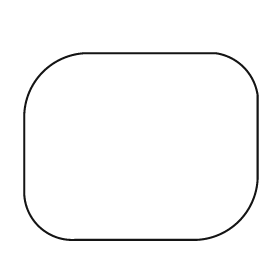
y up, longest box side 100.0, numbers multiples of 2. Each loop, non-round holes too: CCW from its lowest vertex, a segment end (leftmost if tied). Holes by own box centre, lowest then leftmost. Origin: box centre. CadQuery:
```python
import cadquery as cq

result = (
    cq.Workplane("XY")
    .moveTo(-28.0, -40.0)
    .lineTo(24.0, -40.0)
    .threePointArc((42.0, -32.0), (50.0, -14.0))
    .lineTo(50.0, 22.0)
    .threePointArc((44.0, 34.0), (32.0, 40.0))
    .lineTo(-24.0, 40.0)
    .threePointArc((-42.0, 32.0), (-50.0, 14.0))
    .lineTo(-50.0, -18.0)
    .threePointArc((-44.0, -34.0), (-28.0, -40.0))
    .close()
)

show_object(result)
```